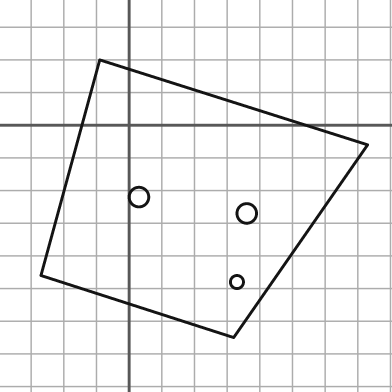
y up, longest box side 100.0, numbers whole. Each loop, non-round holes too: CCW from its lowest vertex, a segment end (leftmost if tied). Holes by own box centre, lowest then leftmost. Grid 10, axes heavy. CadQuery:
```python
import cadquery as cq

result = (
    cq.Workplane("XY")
    .moveTo(32.0, -65.0)
    .lineTo(73.0, -6.0)
    .lineTo(-9.0, 20.0)
    .lineTo(-27.0, -46.0)
    .close()
    .moveTo(33.0, -48.0)
    .circle(2.0)
    .moveTo(36.0, -27.0)
    .circle(3.0)
    .moveTo(3.0, -22.0)
    .circle(3.0)
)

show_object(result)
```